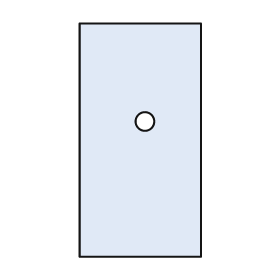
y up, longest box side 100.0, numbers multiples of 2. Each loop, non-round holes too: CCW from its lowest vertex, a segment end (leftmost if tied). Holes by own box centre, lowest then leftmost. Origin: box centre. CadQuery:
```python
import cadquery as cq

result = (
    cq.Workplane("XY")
    .moveTo(-26.0, -50.0)
    .lineTo(26.0, -50.0)
    .lineTo(26.0, 50.0)
    .lineTo(-26.0, 50.0)
    .close()
    .moveTo(2.0, 8.0)
    .circle(4.0)
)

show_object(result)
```